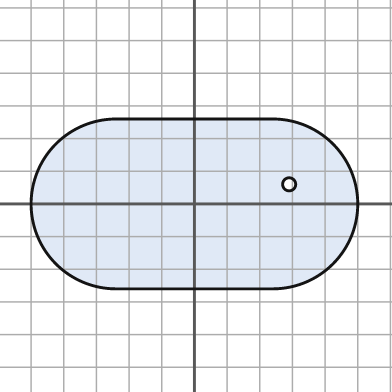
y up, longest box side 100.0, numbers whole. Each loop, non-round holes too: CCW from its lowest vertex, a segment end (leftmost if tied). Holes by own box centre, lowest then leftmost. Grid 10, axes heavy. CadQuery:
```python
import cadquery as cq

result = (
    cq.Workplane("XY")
    .moveTo(-24.0, -26.0)
    .lineTo(24.0, -26.0)
    .threePointArc((50.0, 0.0), (24.0, 26.0))
    .lineTo(-24.0, 26.0)
    .threePointArc((-50.0, 0.0), (-24.0, -26.0))
    .close()
    .moveTo(29.0, 6.0)
    .circle(2.0)
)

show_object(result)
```